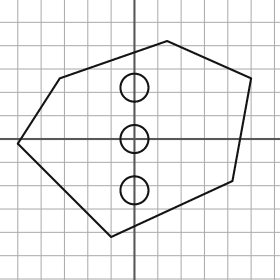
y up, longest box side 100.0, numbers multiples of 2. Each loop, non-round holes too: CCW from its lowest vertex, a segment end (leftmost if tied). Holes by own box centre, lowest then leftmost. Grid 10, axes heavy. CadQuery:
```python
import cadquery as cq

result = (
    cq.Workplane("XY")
    .moveTo(-10.0, -42.0)
    .lineTo(42.0, -18.0)
    .lineTo(50.0, 26.0)
    .lineTo(14.0, 42.0)
    .lineTo(-32.0, 26.0)
    .lineTo(-50.0, -2.0)
    .close()
    .moveTo(0.0, -22.0)
    .circle(6.0)
    .moveTo(0.0, 0.0)
    .circle(6.0)
    .moveTo(0.0, 22.0)
    .circle(6.0)
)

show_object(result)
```